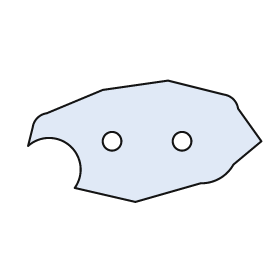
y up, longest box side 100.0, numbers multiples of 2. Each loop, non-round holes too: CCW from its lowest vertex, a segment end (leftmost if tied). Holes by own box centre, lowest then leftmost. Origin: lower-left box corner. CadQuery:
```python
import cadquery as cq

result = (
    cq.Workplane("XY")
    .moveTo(46.0, 0.0)
    .lineTo(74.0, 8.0)
    .threePointArc((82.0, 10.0), (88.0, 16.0))
    .lineTo(100.0, 26.0)
    .lineTo(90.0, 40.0)
    .threePointArc((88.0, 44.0), (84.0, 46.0))
    .lineTo(60.0, 52.0)
    .lineTo(32.0, 48.0)
    .lineTo(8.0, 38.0)
    .threePointArc((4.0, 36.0), (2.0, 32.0))
    .lineTo(0.0, 24.0)
    .threePointArc((18.0, 24.0), (20.0, 6.0))
    .close()
    .moveTo(36.0, 26.0)
    .circle(4.0)
    .moveTo(66.0, 26.0)
    .circle(4.0)
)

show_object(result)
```